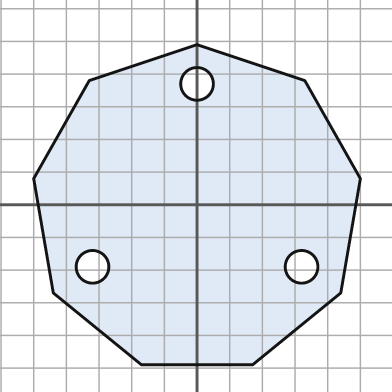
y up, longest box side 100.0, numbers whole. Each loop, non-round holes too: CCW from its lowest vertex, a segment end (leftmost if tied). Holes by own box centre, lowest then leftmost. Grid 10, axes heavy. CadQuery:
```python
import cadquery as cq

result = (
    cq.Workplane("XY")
    .moveTo(-17.0, -49.0)
    .lineTo(17.0, -49.0)
    .lineTo(44.0, -27.0)
    .lineTo(50.0, 8.0)
    .lineTo(33.0, 38.0)
    .lineTo(0.0, 49.0)
    .lineTo(-33.0, 38.0)
    .lineTo(-50.0, 8.0)
    .lineTo(-44.0, -27.0)
    .close()
    .moveTo(-32.0, -19.0)
    .circle(5.0)
    .moveTo(32.0, -19.0)
    .circle(5.0)
    .moveTo(0.0, 37.0)
    .circle(5.0)
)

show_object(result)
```